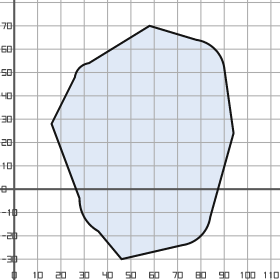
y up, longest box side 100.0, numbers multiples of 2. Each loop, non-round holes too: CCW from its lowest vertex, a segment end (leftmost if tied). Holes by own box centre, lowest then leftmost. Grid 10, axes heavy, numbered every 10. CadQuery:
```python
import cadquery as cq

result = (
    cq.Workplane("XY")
    .moveTo(46.0, -30.0)
    .lineTo(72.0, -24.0)
    .threePointArc((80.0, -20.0), (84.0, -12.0))
    .lineTo(94.0, 24.0)
    .lineTo(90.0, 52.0)
    .threePointArc((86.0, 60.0), (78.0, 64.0))
    .lineTo(58.0, 70.0)
    .lineTo(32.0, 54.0)
    .threePointArc((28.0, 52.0), (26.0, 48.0))
    .lineTo(16.0, 28.0)
    .lineTo(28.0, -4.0)
    .threePointArc((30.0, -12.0), (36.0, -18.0))
    .close()
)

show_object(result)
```